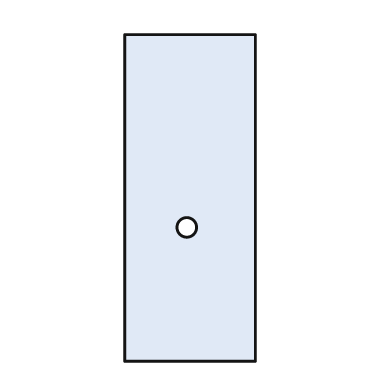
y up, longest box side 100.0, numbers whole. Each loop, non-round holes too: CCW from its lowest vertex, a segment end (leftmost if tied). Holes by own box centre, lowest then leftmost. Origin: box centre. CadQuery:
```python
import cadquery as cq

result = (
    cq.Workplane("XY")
    .moveTo(-20.0, -50.0)
    .lineTo(20.0, -50.0)
    .lineTo(20.0, 50.0)
    .lineTo(-20.0, 50.0)
    .close()
    .moveTo(-1.0, -9.0)
    .circle(3.0)
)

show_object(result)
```